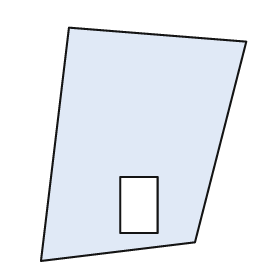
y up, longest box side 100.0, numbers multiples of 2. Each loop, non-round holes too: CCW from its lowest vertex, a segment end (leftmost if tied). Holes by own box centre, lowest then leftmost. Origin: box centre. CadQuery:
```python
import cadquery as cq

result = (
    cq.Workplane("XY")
    .moveTo(-44.0, -50.0)
    .lineTo(22.0, -42.0)
    .lineTo(44.0, 44.0)
    .lineTo(-32.0, 50.0)
    .close()
    .moveTo(-10.0, -38.0)
    .lineTo(6.0, -38.0)
    .lineTo(6.0, -14.0)
    .lineTo(-10.0, -14.0)
    .close()
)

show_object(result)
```